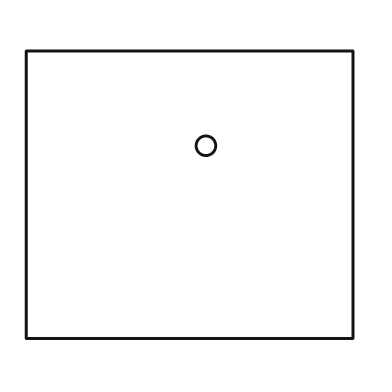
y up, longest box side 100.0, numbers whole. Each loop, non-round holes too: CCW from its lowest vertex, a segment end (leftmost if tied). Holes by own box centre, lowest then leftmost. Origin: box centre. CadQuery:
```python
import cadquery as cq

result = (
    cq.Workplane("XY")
    .moveTo(-50.0, -44.0)
    .lineTo(50.0, -44.0)
    .lineTo(50.0, 44.0)
    .lineTo(-50.0, 44.0)
    .close()
    .moveTo(5.0, 15.0)
    .circle(3.0)
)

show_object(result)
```